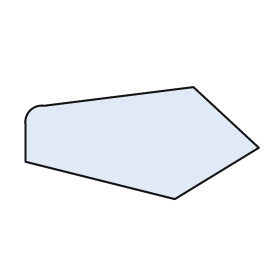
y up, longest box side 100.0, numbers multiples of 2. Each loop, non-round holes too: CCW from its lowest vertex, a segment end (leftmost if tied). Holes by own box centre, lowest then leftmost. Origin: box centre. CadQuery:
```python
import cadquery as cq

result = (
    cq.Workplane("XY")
    .moveTo(14.0, -24.0)
    .lineTo(50.0, -2.0)
    .lineTo(22.0, 24.0)
    .lineTo(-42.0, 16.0)
    .threePointArc((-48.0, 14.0), (-50.0, 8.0))
    .lineTo(-50.0, -8.0)
    .close()
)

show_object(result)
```